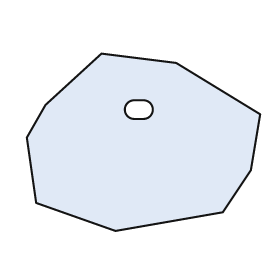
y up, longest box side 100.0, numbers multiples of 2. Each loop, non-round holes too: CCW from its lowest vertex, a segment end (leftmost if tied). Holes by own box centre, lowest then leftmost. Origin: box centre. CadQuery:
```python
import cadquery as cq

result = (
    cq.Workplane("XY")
    .moveTo(-12.0, -38.0)
    .lineTo(34.0, -30.0)
    .lineTo(46.0, -12.0)
    .lineTo(50.0, 12.0)
    .lineTo(14.0, 34.0)
    .lineTo(-18.0, 38.0)
    .lineTo(-42.0, 16.0)
    .lineTo(-50.0, 2.0)
    .lineTo(-46.0, -26.0)
    .close()
    .moveTo(-4.0, 10.0)
    .lineTo(0.0, 10.0)
    .threePointArc((4.0, 14.0), (0.0, 18.0))
    .lineTo(-4.0, 18.0)
    .threePointArc((-8.0, 14.0), (-4.0, 10.0))
    .close()
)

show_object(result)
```